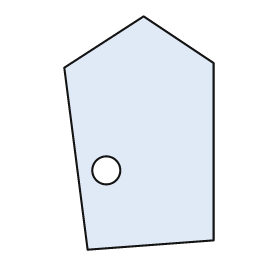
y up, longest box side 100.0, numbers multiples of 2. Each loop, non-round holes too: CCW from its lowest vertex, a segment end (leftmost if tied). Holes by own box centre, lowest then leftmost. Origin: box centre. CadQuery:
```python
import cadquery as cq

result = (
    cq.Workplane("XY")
    .moveTo(-22.0, -50.0)
    .lineTo(32.0, -46.0)
    .lineTo(32.0, 30.0)
    .lineTo(2.0, 50.0)
    .lineTo(-32.0, 28.0)
    .close()
    .moveTo(-14.0, -16.0)
    .circle(6.0)
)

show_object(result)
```